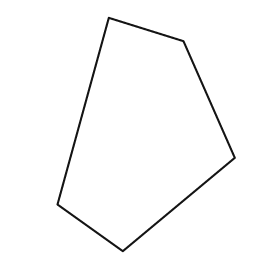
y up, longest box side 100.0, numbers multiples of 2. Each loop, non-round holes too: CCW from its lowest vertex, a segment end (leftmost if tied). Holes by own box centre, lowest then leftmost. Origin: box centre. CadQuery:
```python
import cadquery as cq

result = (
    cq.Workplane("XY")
    .moveTo(-10.0, -50.0)
    .lineTo(38.0, -10.0)
    .lineTo(16.0, 40.0)
    .lineTo(-16.0, 50.0)
    .lineTo(-38.0, -30.0)
    .close()
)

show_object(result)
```